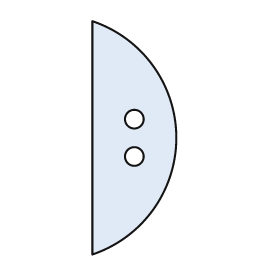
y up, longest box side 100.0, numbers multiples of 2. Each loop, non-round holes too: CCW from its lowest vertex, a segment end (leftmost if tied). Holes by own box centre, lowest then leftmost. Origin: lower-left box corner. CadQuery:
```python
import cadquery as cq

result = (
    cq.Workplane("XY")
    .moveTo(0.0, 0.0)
    .threePointArc((36.0, 50.0), (0.0, 100.0))
    .close()
    .moveTo(18.0, 42.0)
    .circle(4.0)
    .moveTo(18.0, 58.0)
    .circle(4.0)
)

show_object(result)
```